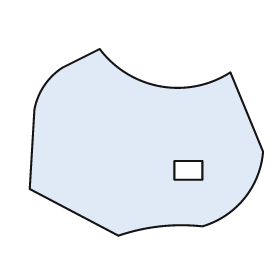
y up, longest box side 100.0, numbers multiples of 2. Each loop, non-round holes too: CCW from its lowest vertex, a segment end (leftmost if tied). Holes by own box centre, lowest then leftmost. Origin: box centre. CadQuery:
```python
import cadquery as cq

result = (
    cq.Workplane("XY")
    .moveTo(-12.0, -40.0)
    .threePointArc((6.0, -36.0), (24.0, -36.0))
    .threePointArc((42.0, -24.0), (50.0, -4.0))
    .lineTo(36.0, 30.0)
    .threePointArc((6.0, 24.0), (-20.0, 40.0))
    .lineTo(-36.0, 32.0)
    .threePointArc((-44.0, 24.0), (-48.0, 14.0))
    .lineTo(-50.0, -20.0)
    .close()
    .moveTo(12.0, -16.0)
    .lineTo(24.0, -16.0)
    .lineTo(24.0, -8.0)
    .lineTo(12.0, -8.0)
    .close()
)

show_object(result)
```